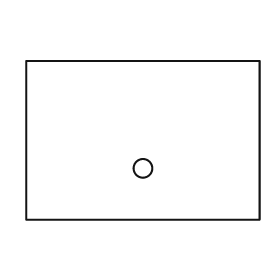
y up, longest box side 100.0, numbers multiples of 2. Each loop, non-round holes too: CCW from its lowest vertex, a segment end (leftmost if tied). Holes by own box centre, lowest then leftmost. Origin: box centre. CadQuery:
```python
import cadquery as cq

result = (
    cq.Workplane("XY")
    .moveTo(-50.0, -34.0)
    .lineTo(50.0, -34.0)
    .lineTo(50.0, 34.0)
    .lineTo(-50.0, 34.0)
    .close()
    .moveTo(0.0, -12.0)
    .circle(4.0)
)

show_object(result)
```